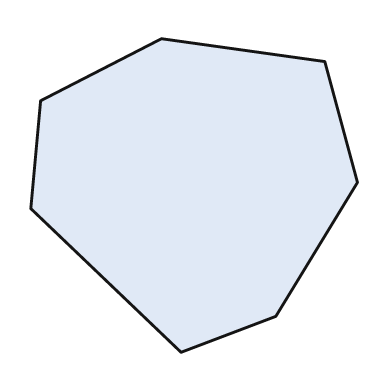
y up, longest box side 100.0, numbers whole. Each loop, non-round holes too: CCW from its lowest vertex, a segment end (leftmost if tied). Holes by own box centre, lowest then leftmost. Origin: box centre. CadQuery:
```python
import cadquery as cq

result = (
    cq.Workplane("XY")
    .moveTo(-4.0, -48.0)
    .lineTo(25.0, -37.0)
    .lineTo(50.0, 4.0)
    .lineTo(40.0, 41.0)
    .lineTo(-10.0, 48.0)
    .lineTo(-47.0, 29.0)
    .lineTo(-50.0, -4.0)
    .close()
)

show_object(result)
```